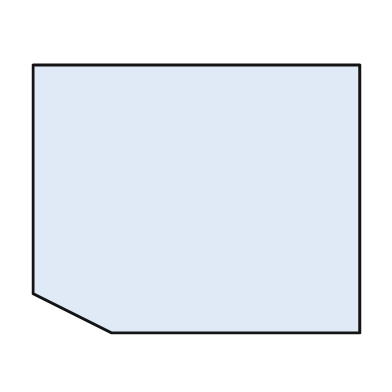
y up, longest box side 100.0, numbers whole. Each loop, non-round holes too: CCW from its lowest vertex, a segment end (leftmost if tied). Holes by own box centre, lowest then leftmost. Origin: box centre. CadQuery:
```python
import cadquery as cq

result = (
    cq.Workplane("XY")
    .moveTo(-26.0, -41.0)
    .lineTo(50.0, -41.0)
    .lineTo(50.0, 41.0)
    .lineTo(-50.0, 41.0)
    .lineTo(-50.0, -29.0)
    .close()
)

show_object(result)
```